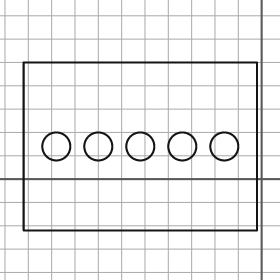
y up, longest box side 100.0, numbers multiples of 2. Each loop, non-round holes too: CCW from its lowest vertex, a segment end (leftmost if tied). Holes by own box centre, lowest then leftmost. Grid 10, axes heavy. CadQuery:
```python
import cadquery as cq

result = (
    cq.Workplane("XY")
    .moveTo(-102.0, -22.0)
    .lineTo(-2.0, -22.0)
    .lineTo(-2.0, 50.0)
    .lineTo(-102.0, 50.0)
    .close()
    .moveTo(-88.0, 14.0)
    .circle(6.0)
    .moveTo(-70.0, 14.0)
    .circle(6.0)
    .moveTo(-52.0, 14.0)
    .circle(6.0)
    .moveTo(-34.0, 14.0)
    .circle(6.0)
    .moveTo(-16.0, 14.0)
    .circle(6.0)
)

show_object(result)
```